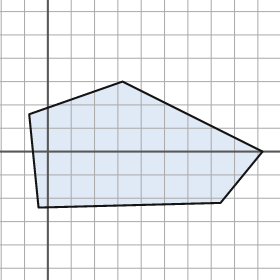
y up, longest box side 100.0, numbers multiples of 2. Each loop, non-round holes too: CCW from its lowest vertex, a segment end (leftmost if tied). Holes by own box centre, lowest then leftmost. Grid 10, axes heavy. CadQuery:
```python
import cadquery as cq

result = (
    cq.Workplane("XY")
    .moveTo(-4.0, -24.0)
    .lineTo(74.0, -22.0)
    .lineTo(92.0, 0.0)
    .lineTo(32.0, 30.0)
    .lineTo(-8.0, 16.0)
    .close()
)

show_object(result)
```